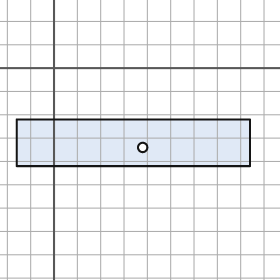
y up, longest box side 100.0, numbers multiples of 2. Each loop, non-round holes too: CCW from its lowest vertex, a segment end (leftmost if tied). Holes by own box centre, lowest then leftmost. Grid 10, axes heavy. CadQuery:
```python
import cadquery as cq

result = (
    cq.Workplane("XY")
    .moveTo(-16.0, -42.0)
    .lineTo(84.0, -42.0)
    .lineTo(84.0, -22.0)
    .lineTo(-16.0, -22.0)
    .close()
    .moveTo(38.0, -34.0)
    .circle(2.0)
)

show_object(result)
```